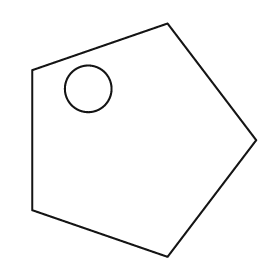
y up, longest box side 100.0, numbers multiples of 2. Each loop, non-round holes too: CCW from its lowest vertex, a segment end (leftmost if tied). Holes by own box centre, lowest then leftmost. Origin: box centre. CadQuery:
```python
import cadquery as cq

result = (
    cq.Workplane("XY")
    .moveTo(10.0, -50.0)
    .lineTo(48.0, 0.0)
    .lineTo(10.0, 50.0)
    .lineTo(-48.0, 30.0)
    .lineTo(-48.0, -30.0)
    .close()
    .moveTo(-24.0, 22.0)
    .circle(10.0)
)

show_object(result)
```